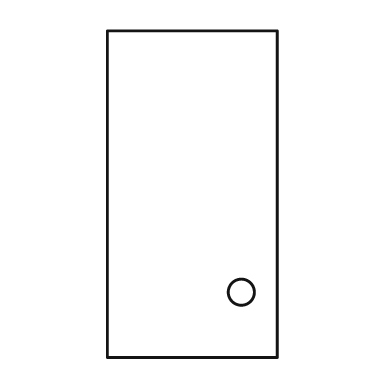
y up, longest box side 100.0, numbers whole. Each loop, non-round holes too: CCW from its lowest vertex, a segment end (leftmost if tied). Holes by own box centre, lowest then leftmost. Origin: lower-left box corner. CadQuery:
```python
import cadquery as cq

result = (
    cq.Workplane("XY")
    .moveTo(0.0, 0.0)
    .lineTo(52.0, 0.0)
    .lineTo(52.0, 100.0)
    .lineTo(0.0, 100.0)
    .close()
    .moveTo(41.0, 20.0)
    .circle(4.0)
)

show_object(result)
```